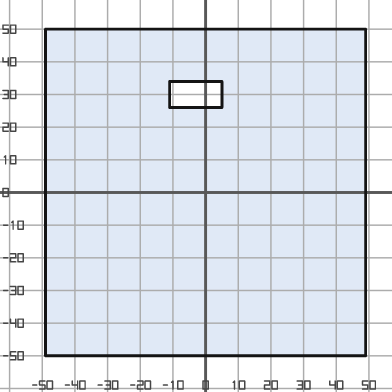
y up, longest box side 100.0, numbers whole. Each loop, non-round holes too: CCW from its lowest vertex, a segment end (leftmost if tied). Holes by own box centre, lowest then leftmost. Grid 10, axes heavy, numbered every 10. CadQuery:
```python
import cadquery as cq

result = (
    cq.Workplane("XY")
    .moveTo(-49.0, -50.0)
    .lineTo(49.0, -50.0)
    .lineTo(49.0, 50.0)
    .lineTo(-49.0, 50.0)
    .close()
    .moveTo(-11.0, 26.0)
    .lineTo(5.0, 26.0)
    .lineTo(5.0, 34.0)
    .lineTo(-11.0, 34.0)
    .close()
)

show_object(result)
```